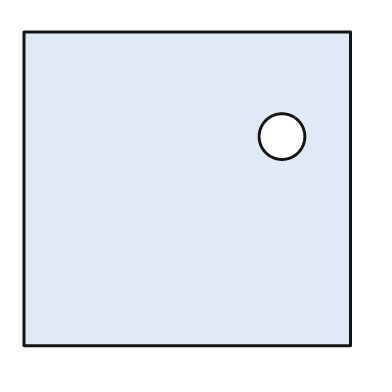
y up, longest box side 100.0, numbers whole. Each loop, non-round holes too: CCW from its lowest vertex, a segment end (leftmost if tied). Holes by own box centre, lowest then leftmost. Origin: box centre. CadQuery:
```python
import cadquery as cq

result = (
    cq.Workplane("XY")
    .moveTo(-50.0, -48.0)
    .lineTo(50.0, -48.0)
    .lineTo(50.0, 48.0)
    .lineTo(-50.0, 48.0)
    .close()
    .moveTo(29.0, 16.0)
    .circle(7.0)
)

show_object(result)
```